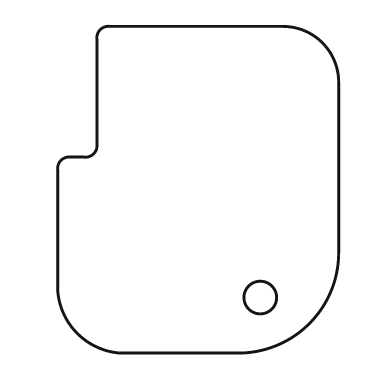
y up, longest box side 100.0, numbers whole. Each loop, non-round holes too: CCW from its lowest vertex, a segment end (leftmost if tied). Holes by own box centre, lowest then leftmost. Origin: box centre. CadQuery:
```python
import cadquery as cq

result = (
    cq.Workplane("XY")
    .moveTo(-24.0, -50.0)
    .lineTo(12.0, -50.0)
    .threePointArc((34.0, -41.0), (43.0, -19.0))
    .lineTo(43.0, 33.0)
    .threePointArc((38.0, 45.0), (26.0, 50.0))
    .lineTo(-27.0, 50.0)
    .threePointArc((-30.0, 49.0), (-31.0, 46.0))
    .lineTo(-31.0, 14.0)
    .threePointArc((-32.0, 11.0), (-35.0, 10.0))
    .lineTo(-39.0, 10.0)
    .threePointArc((-42.0, 9.0), (-43.0, 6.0))
    .lineTo(-43.0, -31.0)
    .threePointArc((-37.0, -44.0), (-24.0, -50.0))
    .close()
    .moveTo(19.0, -33.0)
    .circle(5.0)
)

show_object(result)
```